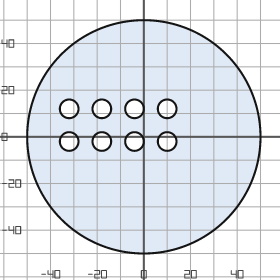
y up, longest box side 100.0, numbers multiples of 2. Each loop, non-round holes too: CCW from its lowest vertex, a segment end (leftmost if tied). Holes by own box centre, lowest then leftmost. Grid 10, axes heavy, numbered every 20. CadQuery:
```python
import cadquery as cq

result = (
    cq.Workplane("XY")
    .moveTo(0.0, 0.0)
    .circle(50.0)
    .moveTo(-32.0, -2.0)
    .circle(4.0)
    .moveTo(-18.0, -2.0)
    .circle(4.0)
    .moveTo(-4.0, -2.0)
    .circle(4.0)
    .moveTo(10.0, -2.0)
    .circle(4.0)
    .moveTo(-32.0, 12.0)
    .circle(4.0)
    .moveTo(-18.0, 12.0)
    .circle(4.0)
    .moveTo(-4.0, 12.0)
    .circle(4.0)
    .moveTo(10.0, 12.0)
    .circle(4.0)
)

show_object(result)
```